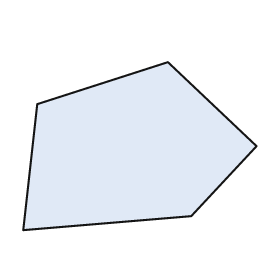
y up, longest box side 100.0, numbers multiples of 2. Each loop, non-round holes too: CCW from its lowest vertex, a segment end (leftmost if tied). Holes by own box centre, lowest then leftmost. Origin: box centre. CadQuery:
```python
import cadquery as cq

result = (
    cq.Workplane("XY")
    .moveTo(-50.0, -36.0)
    .lineTo(22.0, -30.0)
    .lineTo(50.0, 0.0)
    .lineTo(12.0, 36.0)
    .lineTo(-44.0, 18.0)
    .close()
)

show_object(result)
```